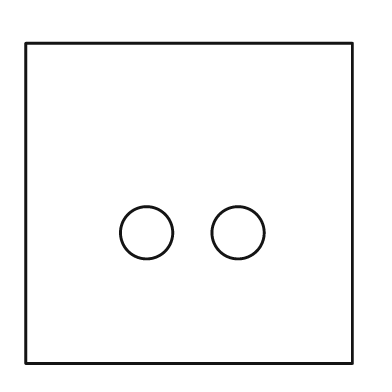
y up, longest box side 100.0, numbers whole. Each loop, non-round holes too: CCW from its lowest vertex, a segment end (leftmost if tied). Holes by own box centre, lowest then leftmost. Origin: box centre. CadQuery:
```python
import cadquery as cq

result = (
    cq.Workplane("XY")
    .moveTo(-50.0, -49.0)
    .lineTo(50.0, -49.0)
    .lineTo(50.0, 49.0)
    .lineTo(-50.0, 49.0)
    .close()
    .moveTo(-13.0, -9.0)
    .circle(8.0)
    .moveTo(15.0, -9.0)
    .circle(8.0)
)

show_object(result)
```